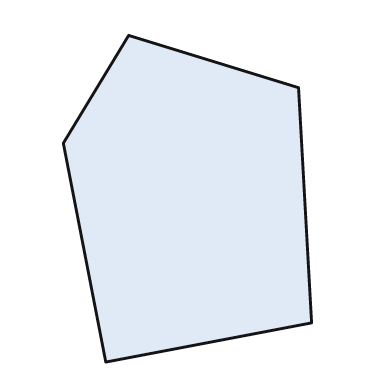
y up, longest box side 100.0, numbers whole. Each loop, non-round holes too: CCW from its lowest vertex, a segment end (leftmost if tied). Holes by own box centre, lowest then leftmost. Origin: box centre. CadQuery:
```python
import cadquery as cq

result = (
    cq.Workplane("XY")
    .moveTo(-25.0, -50.0)
    .lineTo(38.0, -38.0)
    .lineTo(34.0, 34.0)
    .lineTo(-18.0, 50.0)
    .lineTo(-38.0, 17.0)
    .close()
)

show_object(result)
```